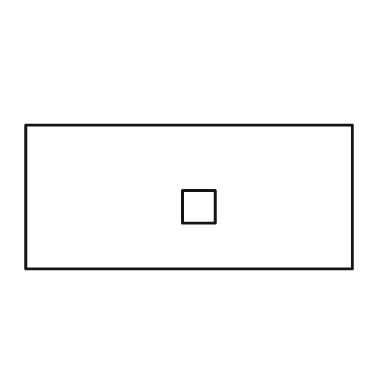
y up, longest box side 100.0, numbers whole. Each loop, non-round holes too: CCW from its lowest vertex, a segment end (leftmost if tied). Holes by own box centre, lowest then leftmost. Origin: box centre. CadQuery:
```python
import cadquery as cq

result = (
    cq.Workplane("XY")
    .moveTo(-50.0, -22.0)
    .lineTo(50.0, -22.0)
    .lineTo(50.0, 22.0)
    .lineTo(-50.0, 22.0)
    .close()
    .moveTo(-2.0, -8.0)
    .lineTo(8.0, -8.0)
    .lineTo(8.0, 2.0)
    .lineTo(-2.0, 2.0)
    .close()
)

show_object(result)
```